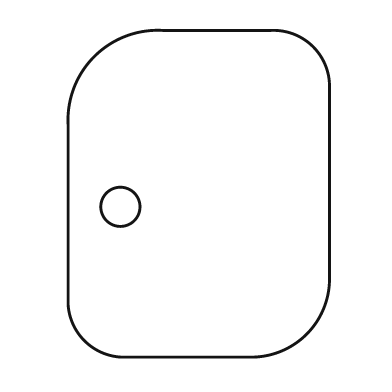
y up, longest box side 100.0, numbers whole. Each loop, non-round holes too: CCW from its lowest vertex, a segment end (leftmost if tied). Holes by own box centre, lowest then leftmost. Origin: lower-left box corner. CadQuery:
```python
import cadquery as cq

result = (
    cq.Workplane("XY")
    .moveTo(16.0, 0.0)
    .lineTo(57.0, 0.0)
    .threePointArc((73.0, 7.0), (80.0, 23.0))
    .lineTo(80.0, 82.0)
    .threePointArc((75.0, 95.0), (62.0, 100.0))
    .lineTo(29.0, 100.0)
    .threePointArc((8.0, 92.0), (0.0, 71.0))
    .lineTo(0.0, 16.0)
    .threePointArc((5.0, 5.0), (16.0, 0.0))
    .close()
    .moveTo(16.0, 46.0)
    .circle(6.0)
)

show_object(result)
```